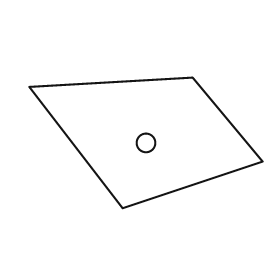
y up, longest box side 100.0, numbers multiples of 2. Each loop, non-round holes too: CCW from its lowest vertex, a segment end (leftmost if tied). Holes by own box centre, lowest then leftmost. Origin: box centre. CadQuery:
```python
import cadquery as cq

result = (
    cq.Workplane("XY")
    .moveTo(-10.0, -28.0)
    .lineTo(50.0, -8.0)
    .lineTo(20.0, 28.0)
    .lineTo(-50.0, 24.0)
    .close()
    .moveTo(0.0, 0.0)
    .circle(4.0)
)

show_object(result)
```